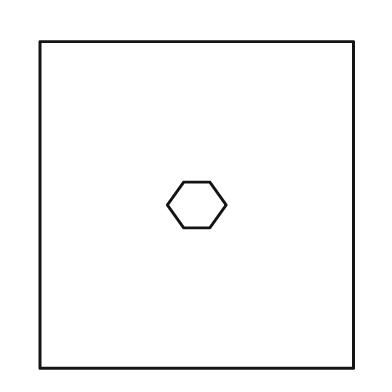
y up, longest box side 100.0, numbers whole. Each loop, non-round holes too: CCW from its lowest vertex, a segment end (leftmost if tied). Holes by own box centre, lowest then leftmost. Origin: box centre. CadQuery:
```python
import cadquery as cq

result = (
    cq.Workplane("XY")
    .moveTo(-48.0, -50.0)
    .lineTo(48.0, -50.0)
    .lineTo(48.0, 50.0)
    .lineTo(-48.0, 50.0)
    .close()
    .moveTo(-4.0, -7.0)
    .lineTo(4.0, -7.0)
    .lineTo(9.0, 0.0)
    .lineTo(4.0, 7.0)
    .lineTo(-4.0, 7.0)
    .lineTo(-9.0, 0.0)
    .close()
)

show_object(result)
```